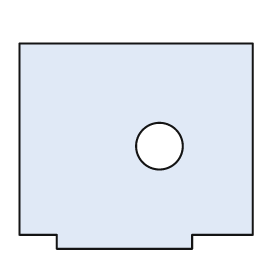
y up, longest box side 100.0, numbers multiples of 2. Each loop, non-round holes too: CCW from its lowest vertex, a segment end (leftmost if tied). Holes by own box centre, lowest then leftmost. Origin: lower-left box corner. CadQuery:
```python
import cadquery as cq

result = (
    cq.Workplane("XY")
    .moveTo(16.0, 0.0)
    .lineTo(74.0, 0.0)
    .lineTo(74.0, 6.0)
    .lineTo(100.0, 6.0)
    .lineTo(100.0, 88.0)
    .lineTo(0.0, 88.0)
    .lineTo(0.0, 6.0)
    .lineTo(16.0, 6.0)
    .close()
    .moveTo(60.0, 44.0)
    .circle(10.0)
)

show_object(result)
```